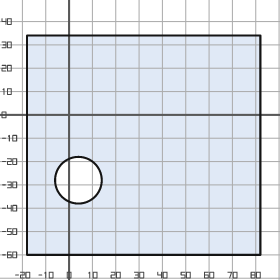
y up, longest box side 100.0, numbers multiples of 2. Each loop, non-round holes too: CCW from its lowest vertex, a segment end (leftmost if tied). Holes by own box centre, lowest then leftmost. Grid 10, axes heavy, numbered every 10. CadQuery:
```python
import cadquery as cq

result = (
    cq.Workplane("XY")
    .moveTo(-18.0, -60.0)
    .lineTo(82.0, -60.0)
    .lineTo(82.0, 34.0)
    .lineTo(-18.0, 34.0)
    .close()
    .moveTo(4.0, -28.0)
    .circle(10.0)
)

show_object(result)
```